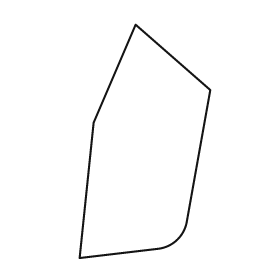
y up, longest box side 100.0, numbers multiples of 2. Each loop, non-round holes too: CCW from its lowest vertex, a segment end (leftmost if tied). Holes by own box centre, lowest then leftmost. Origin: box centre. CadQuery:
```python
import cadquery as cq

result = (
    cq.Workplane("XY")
    .moveTo(-28.0, -50.0)
    .lineTo(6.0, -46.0)
    .threePointArc((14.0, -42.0), (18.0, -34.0))
    .lineTo(28.0, 22.0)
    .lineTo(-4.0, 50.0)
    .lineTo(-22.0, 8.0)
    .close()
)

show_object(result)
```